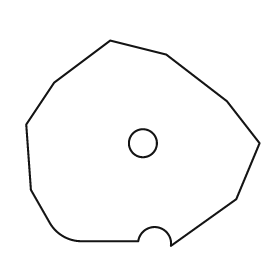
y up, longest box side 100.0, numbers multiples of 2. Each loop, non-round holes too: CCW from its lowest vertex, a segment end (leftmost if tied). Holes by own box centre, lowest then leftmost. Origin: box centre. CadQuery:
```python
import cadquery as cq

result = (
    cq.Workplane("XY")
    .moveTo(12.0, -44.0)
    .lineTo(40.0, -24.0)
    .lineTo(50.0, 0.0)
    .lineTo(36.0, 18.0)
    .lineTo(10.0, 38.0)
    .lineTo(-14.0, 44.0)
    .lineTo(-38.0, 26.0)
    .lineTo(-50.0, 8.0)
    .lineTo(-48.0, -20.0)
    .lineTo(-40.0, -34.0)
    .threePointArc((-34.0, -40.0), (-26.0, -42.0))
    .lineTo(-2.0, -42.0)
    .threePointArc((6.0, -36.0), (12.0, -44.0))
    .close()
    .moveTo(0.0, 0.0)
    .circle(6.0)
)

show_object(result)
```